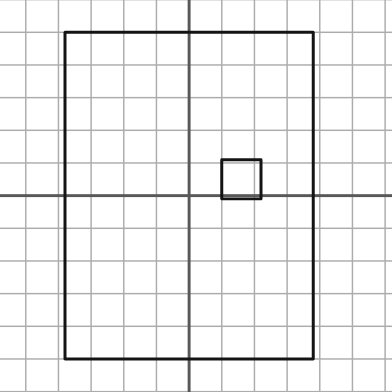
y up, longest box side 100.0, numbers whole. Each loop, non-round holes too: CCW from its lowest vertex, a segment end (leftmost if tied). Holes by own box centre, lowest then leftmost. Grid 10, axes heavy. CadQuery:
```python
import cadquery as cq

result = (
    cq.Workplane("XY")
    .moveTo(-38.0, -50.0)
    .lineTo(38.0, -50.0)
    .lineTo(38.0, 50.0)
    .lineTo(-38.0, 50.0)
    .close()
    .moveTo(10.0, -1.0)
    .lineTo(22.0, -1.0)
    .lineTo(22.0, 11.0)
    .lineTo(10.0, 11.0)
    .close()
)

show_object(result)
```